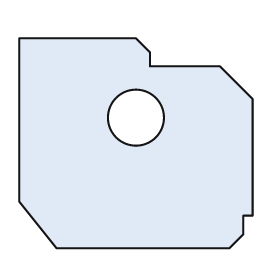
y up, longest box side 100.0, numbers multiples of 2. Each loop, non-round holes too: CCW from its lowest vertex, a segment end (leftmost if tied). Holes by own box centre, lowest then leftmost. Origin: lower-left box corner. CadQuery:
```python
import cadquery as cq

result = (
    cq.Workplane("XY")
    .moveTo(16.0, 0.0)
    .lineTo(90.0, 0.0)
    .lineTo(96.0, 6.0)
    .lineTo(96.0, 14.0)
    .lineTo(100.0, 14.0)
    .lineTo(100.0, 64.0)
    .lineTo(86.0, 78.0)
    .lineTo(56.0, 78.0)
    .lineTo(56.0, 84.0)
    .lineTo(50.0, 90.0)
    .lineTo(0.0, 90.0)
    .lineTo(0.0, 20.0)
    .close()
    .moveTo(50.0, 56.0)
    .circle(12.0)
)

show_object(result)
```